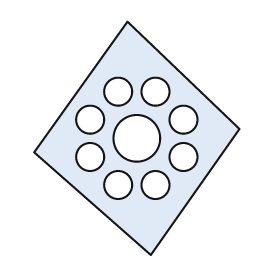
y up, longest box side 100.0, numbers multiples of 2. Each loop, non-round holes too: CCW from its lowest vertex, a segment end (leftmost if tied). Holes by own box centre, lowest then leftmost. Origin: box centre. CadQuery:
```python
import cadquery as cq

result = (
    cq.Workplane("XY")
    .moveTo(6.0, -50.0)
    .lineTo(44.0, 4.0)
    .lineTo(-4.0, 50.0)
    .lineTo(-44.0, -6.0)
    .close()
    .moveTo(-8.0, -20.0)
    .circle(6.0)
    .moveTo(8.0, -20.0)
    .circle(6.0)
    .moveTo(-20.0, -8.0)
    .circle(6.0)
    .moveTo(20.0, -8.0)
    .circle(6.0)
    .moveTo(0.0, 0.0)
    .circle(10.0)
    .moveTo(-20.0, 8.0)
    .circle(6.0)
    .moveTo(20.0, 8.0)
    .circle(6.0)
    .moveTo(-8.0, 20.0)
    .circle(6.0)
    .moveTo(8.0, 20.0)
    .circle(6.0)
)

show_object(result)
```